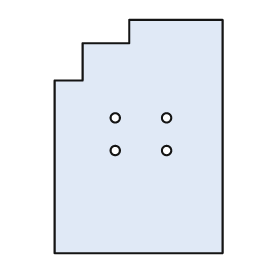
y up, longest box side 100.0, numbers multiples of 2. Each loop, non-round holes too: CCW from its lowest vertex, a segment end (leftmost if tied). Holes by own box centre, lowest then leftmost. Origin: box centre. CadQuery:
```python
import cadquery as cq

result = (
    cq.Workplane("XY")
    .moveTo(-36.0, -50.0)
    .lineTo(36.0, -50.0)
    .lineTo(36.0, 50.0)
    .lineTo(-4.0, 50.0)
    .lineTo(-4.0, 40.0)
    .lineTo(-24.0, 40.0)
    .lineTo(-24.0, 24.0)
    .lineTo(-36.0, 24.0)
    .close()
    .moveTo(-10.0, -6.0)
    .circle(2.0)
    .moveTo(12.0, -6.0)
    .circle(2.0)
    .moveTo(-10.0, 8.0)
    .circle(2.0)
    .moveTo(12.0, 8.0)
    .circle(2.0)
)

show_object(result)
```